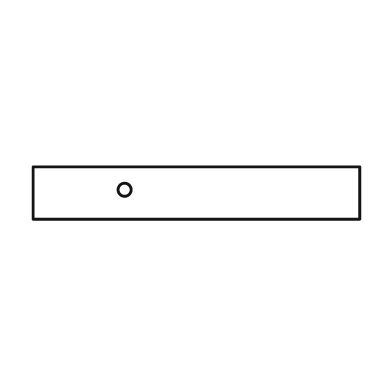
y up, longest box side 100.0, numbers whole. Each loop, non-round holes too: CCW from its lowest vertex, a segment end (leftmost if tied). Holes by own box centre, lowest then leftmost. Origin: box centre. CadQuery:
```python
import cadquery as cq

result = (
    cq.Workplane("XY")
    .moveTo(-50.0, -8.0)
    .lineTo(50.0, -8.0)
    .lineTo(50.0, 8.0)
    .lineTo(-50.0, 8.0)
    .close()
    .moveTo(-22.0, 1.0)
    .circle(2.0)
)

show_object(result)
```